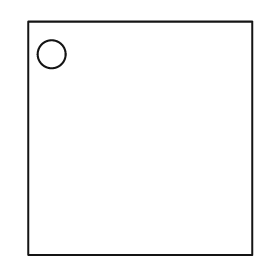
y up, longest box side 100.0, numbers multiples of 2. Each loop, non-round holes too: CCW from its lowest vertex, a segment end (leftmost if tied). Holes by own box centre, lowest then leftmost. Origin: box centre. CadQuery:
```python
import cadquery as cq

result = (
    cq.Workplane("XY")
    .moveTo(-48.0, -50.0)
    .lineTo(48.0, -50.0)
    .lineTo(48.0, 50.0)
    .lineTo(-48.0, 50.0)
    .close()
    .moveTo(-38.0, 36.0)
    .circle(6.0)
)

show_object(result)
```